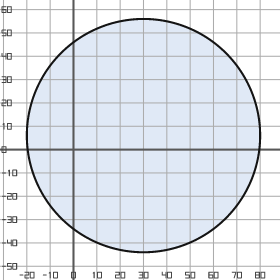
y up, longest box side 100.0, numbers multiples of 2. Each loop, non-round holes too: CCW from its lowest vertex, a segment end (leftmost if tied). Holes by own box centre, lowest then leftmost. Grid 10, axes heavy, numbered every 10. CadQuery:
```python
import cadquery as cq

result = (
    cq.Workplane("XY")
    .moveTo(30.0, 6.0)
    .circle(50.0)
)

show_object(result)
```